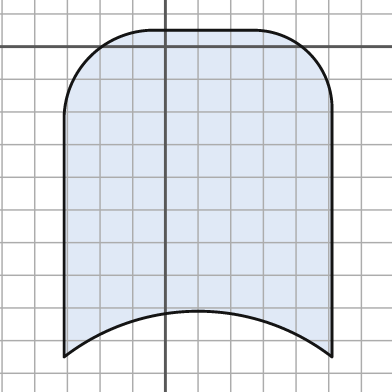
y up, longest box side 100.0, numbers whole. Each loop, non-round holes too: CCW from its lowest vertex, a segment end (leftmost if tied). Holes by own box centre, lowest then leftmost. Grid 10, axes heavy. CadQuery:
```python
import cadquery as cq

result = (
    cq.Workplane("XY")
    .moveTo(-31.0, -95.0)
    .threePointArc((10.0, -81.0), (51.0, -95.0))
    .lineTo(51.0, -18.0)
    .threePointArc((44.0, -2.0), (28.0, 5.0))
    .lineTo(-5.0, 5.0)
    .threePointArc((-23.0, -3.0), (-31.0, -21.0))
    .close()
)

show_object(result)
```